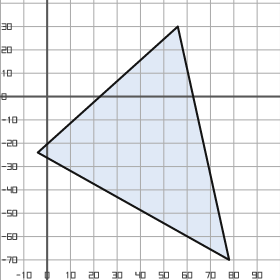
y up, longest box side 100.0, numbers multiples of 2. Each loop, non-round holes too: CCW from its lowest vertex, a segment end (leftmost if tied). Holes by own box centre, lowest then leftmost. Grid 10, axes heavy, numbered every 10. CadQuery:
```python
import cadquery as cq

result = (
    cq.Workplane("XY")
    .moveTo(78.0, -70.0)
    .lineTo(56.0, 30.0)
    .lineTo(-4.0, -24.0)
    .close()
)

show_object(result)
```